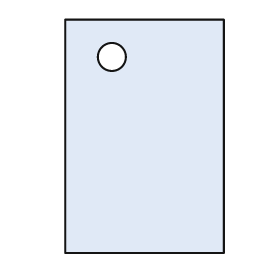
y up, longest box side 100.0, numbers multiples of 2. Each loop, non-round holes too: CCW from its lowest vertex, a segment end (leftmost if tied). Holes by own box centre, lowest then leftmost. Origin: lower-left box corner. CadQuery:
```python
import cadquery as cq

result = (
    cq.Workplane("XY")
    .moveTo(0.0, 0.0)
    .lineTo(68.0, 0.0)
    .lineTo(68.0, 100.0)
    .lineTo(0.0, 100.0)
    .close()
    .moveTo(20.0, 84.0)
    .circle(6.0)
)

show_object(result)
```